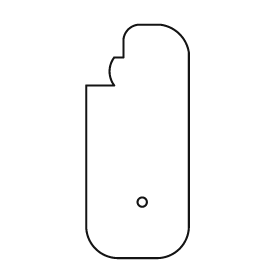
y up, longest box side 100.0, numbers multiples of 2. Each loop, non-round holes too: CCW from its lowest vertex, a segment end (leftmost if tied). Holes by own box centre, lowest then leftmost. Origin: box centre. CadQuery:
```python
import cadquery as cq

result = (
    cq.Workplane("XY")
    .moveTo(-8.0, -50.0)
    .lineTo(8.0, -50.0)
    .threePointArc((18.0, -46.0), (22.0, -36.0))
    .lineTo(22.0, 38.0)
    .threePointArc((18.0, 46.0), (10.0, 50.0))
    .lineTo(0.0, 50.0)
    .threePointArc((-4.0, 48.0), (-6.0, 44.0))
    .lineTo(-6.0, 36.0)
    .lineTo(-10.0, 36.0)
    .threePointArc((-12.0, 30.0), (-10.0, 24.0))
    .lineTo(-22.0, 24.0)
    .lineTo(-22.0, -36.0)
    .threePointArc((-18.0, -46.0), (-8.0, -50.0))
    .close()
    .moveTo(2.0, -26.0)
    .circle(2.0)
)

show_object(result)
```